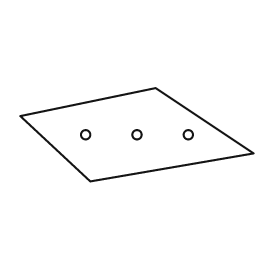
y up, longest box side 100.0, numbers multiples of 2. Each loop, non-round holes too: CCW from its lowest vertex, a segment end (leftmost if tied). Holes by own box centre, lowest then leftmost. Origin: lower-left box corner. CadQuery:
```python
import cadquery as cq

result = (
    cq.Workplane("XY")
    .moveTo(30.0, 0.0)
    .lineTo(100.0, 12.0)
    .lineTo(58.0, 40.0)
    .lineTo(0.0, 28.0)
    .close()
    .moveTo(28.0, 20.0)
    .circle(2.0)
    .moveTo(50.0, 20.0)
    .circle(2.0)
    .moveTo(72.0, 20.0)
    .circle(2.0)
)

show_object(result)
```